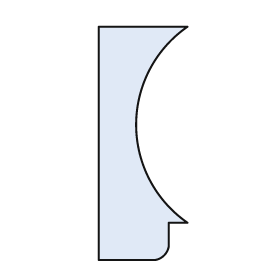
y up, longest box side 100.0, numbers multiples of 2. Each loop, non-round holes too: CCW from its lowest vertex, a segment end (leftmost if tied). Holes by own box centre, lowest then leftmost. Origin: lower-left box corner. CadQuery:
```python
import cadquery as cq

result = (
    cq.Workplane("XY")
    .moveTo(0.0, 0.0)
    .lineTo(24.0, 0.0)
    .threePointArc((28.0, 2.0), (30.0, 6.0))
    .lineTo(30.0, 16.0)
    .lineTo(38.0, 16.0)
    .threePointArc((16.0, 58.0), (38.0, 100.0))
    .lineTo(0.0, 100.0)
    .close()
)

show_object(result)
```